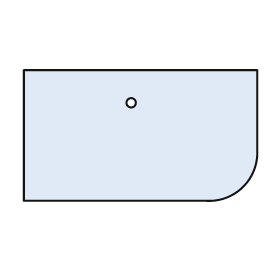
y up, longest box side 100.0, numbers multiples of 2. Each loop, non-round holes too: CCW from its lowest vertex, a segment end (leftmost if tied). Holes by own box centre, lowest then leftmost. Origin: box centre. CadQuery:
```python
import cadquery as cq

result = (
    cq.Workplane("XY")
    .moveTo(-50.0, -28.0)
    .lineTo(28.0, -28.0)
    .threePointArc((44.0, -22.0), (50.0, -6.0))
    .lineTo(50.0, 28.0)
    .lineTo(-50.0, 28.0)
    .close()
    .moveTo(-4.0, 14.0)
    .circle(2.0)
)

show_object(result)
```